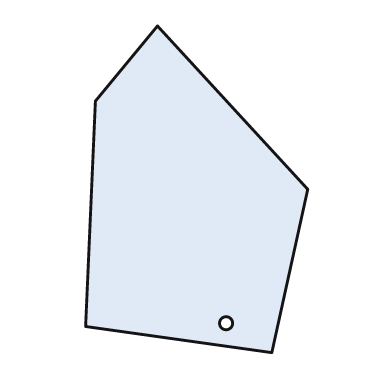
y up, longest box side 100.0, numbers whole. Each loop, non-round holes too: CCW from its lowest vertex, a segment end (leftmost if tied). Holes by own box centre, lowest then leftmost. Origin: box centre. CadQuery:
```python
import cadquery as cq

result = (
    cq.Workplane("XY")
    .moveTo(23.0, -50.0)
    .lineTo(34.0, 0.0)
    .lineTo(-12.0, 50.0)
    .lineTo(-31.0, 27.0)
    .lineTo(-34.0, -42.0)
    .close()
    .moveTo(9.0, -41.0)
    .circle(2.0)
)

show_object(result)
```